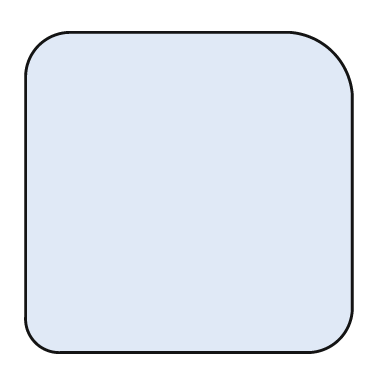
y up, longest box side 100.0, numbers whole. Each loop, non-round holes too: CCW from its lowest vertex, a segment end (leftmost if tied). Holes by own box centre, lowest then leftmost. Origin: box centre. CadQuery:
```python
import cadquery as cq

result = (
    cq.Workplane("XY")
    .moveTo(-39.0, -49.0)
    .lineTo(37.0, -49.0)
    .threePointArc((46.0, -45.0), (50.0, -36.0))
    .lineTo(50.0, 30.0)
    .threePointArc((44.0, 43.0), (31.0, 49.0))
    .lineTo(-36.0, 49.0)
    .threePointArc((-46.0, 45.0), (-50.0, 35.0))
    .lineTo(-50.0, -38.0)
    .threePointArc((-47.0, -46.0), (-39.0, -49.0))
    .close()
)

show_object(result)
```